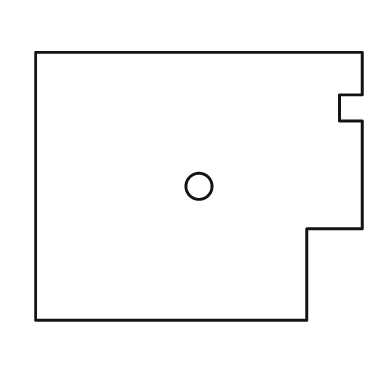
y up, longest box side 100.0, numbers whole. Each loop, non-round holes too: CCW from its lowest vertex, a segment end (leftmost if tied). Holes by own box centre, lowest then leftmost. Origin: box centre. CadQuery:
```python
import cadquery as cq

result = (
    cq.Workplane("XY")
    .moveTo(-50.0, -41.0)
    .lineTo(33.0, -41.0)
    .lineTo(33.0, -13.0)
    .lineTo(50.0, -13.0)
    .lineTo(50.0, 20.0)
    .lineTo(43.0, 20.0)
    .lineTo(43.0, 28.0)
    .lineTo(50.0, 28.0)
    .lineTo(50.0, 41.0)
    .lineTo(-50.0, 41.0)
    .close()
    .moveTo(0.0, 0.0)
    .circle(4.0)
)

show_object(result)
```